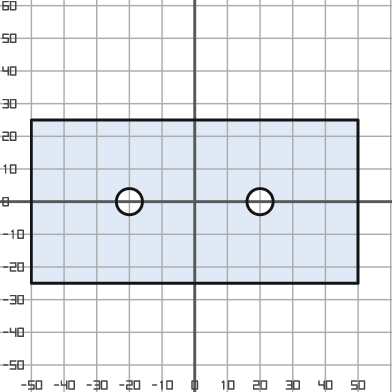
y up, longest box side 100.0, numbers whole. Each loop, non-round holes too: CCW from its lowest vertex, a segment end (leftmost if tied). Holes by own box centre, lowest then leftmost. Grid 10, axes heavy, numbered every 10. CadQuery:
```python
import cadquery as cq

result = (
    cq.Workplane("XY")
    .moveTo(-50.0, -25.0)
    .lineTo(50.0, -25.0)
    .lineTo(50.0, 25.0)
    .lineTo(-50.0, 25.0)
    .close()
    .moveTo(-20.0, 0.0)
    .circle(4.0)
    .moveTo(20.0, 0.0)
    .circle(4.0)
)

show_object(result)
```